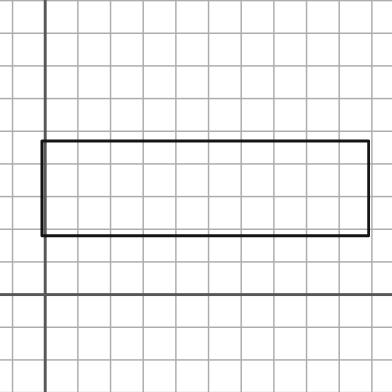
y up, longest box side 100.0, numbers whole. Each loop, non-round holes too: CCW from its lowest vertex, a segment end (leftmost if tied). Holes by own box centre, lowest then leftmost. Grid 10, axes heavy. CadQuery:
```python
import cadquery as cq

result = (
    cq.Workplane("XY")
    .moveTo(-1.0, 18.0)
    .lineTo(99.0, 18.0)
    .lineTo(99.0, 47.0)
    .lineTo(-1.0, 47.0)
    .close()
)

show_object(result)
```